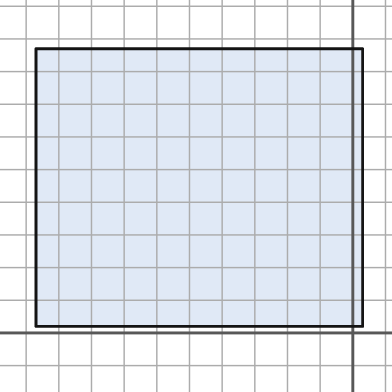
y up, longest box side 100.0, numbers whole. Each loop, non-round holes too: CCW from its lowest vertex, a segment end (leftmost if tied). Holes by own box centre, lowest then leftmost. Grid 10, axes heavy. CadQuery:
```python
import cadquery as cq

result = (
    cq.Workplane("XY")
    .moveTo(-97.0, 2.0)
    .lineTo(3.0, 2.0)
    .lineTo(3.0, 87.0)
    .lineTo(-97.0, 87.0)
    .close()
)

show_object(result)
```